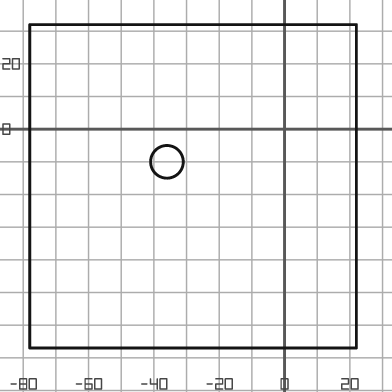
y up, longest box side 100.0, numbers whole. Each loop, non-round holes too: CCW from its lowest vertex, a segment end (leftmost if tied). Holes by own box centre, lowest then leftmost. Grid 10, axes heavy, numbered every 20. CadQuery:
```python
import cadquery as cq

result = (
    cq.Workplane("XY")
    .moveTo(-78.0, -67.0)
    .lineTo(22.0, -67.0)
    .lineTo(22.0, 32.0)
    .lineTo(-78.0, 32.0)
    .close()
    .moveTo(-36.0, -10.0)
    .circle(5.0)
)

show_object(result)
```